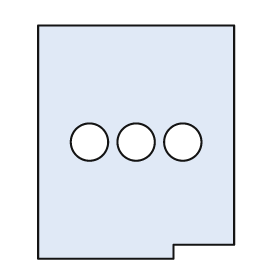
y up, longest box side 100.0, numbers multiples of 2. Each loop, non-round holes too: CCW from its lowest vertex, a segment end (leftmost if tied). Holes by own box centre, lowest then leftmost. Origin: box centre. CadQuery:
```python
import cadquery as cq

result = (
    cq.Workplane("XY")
    .moveTo(-42.0, -50.0)
    .lineTo(16.0, -50.0)
    .lineTo(16.0, -44.0)
    .lineTo(42.0, -44.0)
    .lineTo(42.0, 50.0)
    .lineTo(-42.0, 50.0)
    .close()
    .moveTo(-20.0, 0.0)
    .circle(8.0)
    .moveTo(0.0, 0.0)
    .circle(8.0)
    .moveTo(20.0, 0.0)
    .circle(8.0)
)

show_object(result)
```